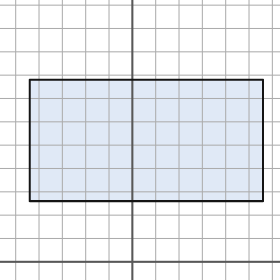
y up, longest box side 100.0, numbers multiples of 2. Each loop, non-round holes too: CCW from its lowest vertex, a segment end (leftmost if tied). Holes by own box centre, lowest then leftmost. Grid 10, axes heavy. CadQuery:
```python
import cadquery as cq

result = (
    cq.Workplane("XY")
    .moveTo(-44.0, 26.0)
    .lineTo(56.0, 26.0)
    .lineTo(56.0, 78.0)
    .lineTo(-44.0, 78.0)
    .close()
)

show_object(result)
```